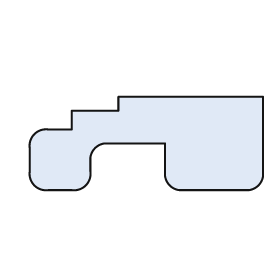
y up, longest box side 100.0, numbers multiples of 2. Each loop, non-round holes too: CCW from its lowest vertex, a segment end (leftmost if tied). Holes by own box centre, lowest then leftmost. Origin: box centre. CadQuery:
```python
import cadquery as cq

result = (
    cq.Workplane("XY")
    .moveTo(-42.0, -20.0)
    .lineTo(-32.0, -20.0)
    .threePointArc((-26.0, -18.0), (-24.0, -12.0))
    .lineTo(-24.0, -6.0)
    .threePointArc((-22.0, -2.0), (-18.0, 0.0))
    .lineTo(8.0, 0.0)
    .lineTo(8.0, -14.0)
    .threePointArc((10.0, -18.0), (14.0, -20.0))
    .lineTo(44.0, -20.0)
    .threePointArc((48.0, -18.0), (50.0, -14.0))
    .lineTo(50.0, 20.0)
    .lineTo(-12.0, 20.0)
    .lineTo(-12.0, 14.0)
    .lineTo(-32.0, 14.0)
    .lineTo(-32.0, 6.0)
    .lineTo(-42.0, 6.0)
    .threePointArc((-48.0, 4.0), (-50.0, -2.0))
    .lineTo(-50.0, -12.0)
    .threePointArc((-48.0, -18.0), (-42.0, -20.0))
    .close()
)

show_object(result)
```